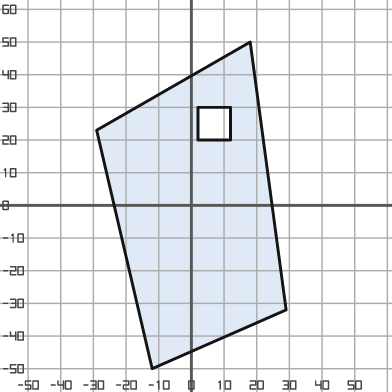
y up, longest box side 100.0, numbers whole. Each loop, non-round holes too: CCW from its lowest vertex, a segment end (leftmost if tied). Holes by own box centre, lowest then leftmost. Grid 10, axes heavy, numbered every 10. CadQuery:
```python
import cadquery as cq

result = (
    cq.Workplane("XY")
    .moveTo(-12.0, -50.0)
    .lineTo(29.0, -32.0)
    .lineTo(18.0, 50.0)
    .lineTo(-29.0, 23.0)
    .close()
    .moveTo(2.0, 20.0)
    .lineTo(12.0, 20.0)
    .lineTo(12.0, 30.0)
    .lineTo(2.0, 30.0)
    .close()
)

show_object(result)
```